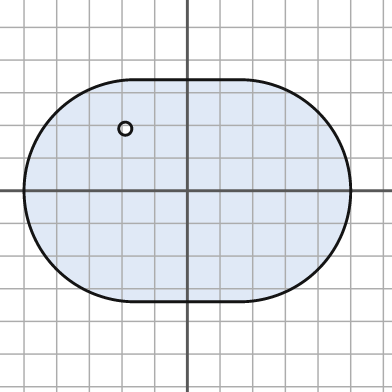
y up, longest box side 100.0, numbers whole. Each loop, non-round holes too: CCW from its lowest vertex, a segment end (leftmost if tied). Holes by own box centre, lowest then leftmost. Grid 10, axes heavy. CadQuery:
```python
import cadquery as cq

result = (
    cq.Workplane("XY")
    .moveTo(-16.0, -34.0)
    .lineTo(16.0, -34.0)
    .threePointArc((50.0, 0.0), (16.0, 34.0))
    .lineTo(-16.0, 34.0)
    .threePointArc((-50.0, 0.0), (-16.0, -34.0))
    .close()
    .moveTo(-19.0, 19.0)
    .circle(2.0)
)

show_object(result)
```